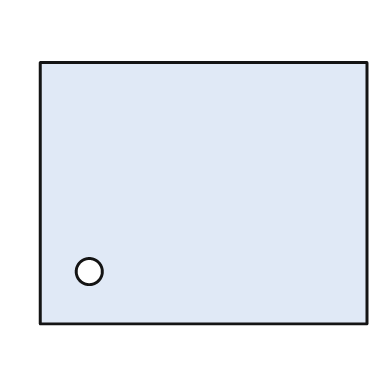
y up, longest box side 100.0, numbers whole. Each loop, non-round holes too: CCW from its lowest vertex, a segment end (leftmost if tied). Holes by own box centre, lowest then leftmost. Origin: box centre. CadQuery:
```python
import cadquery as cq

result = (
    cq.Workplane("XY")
    .moveTo(-50.0, -40.0)
    .lineTo(50.0, -40.0)
    .lineTo(50.0, 40.0)
    .lineTo(-50.0, 40.0)
    .close()
    .moveTo(-35.0, -24.0)
    .circle(4.0)
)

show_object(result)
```